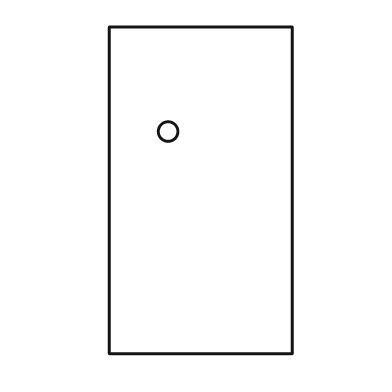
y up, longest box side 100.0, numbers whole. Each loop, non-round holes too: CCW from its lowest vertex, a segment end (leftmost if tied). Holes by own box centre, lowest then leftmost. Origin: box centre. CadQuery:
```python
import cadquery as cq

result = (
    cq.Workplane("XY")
    .moveTo(-28.0, -50.0)
    .lineTo(28.0, -50.0)
    .lineTo(28.0, 50.0)
    .lineTo(-28.0, 50.0)
    .close()
    .moveTo(-10.0, 18.0)
    .circle(3.0)
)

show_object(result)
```